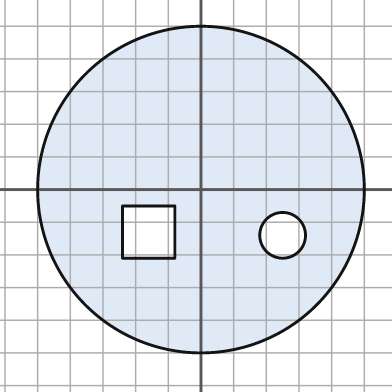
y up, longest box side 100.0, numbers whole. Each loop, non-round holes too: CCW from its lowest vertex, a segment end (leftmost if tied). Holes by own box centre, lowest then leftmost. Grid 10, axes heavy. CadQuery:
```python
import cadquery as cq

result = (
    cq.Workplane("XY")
    .moveTo(0.0, 0.0)
    .circle(50.0)
    .moveTo(25.0, -14.0)
    .circle(7.0)
    .moveTo(-24.0, -21.0)
    .lineTo(-8.0, -21.0)
    .lineTo(-8.0, -5.0)
    .lineTo(-24.0, -5.0)
    .close()
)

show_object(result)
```